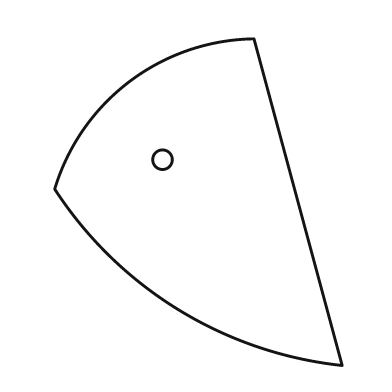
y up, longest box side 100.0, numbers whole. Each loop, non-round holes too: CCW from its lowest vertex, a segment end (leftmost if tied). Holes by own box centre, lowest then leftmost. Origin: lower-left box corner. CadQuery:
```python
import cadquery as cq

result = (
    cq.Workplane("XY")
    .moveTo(88.0, 0.0)
    .lineTo(61.0, 100.0)
    .threePointArc((23.0, 87.0), (0.0, 54.0))
    .threePointArc((38.0, 17.0), (88.0, 0.0))
    .close()
    .moveTo(33.0, 63.0)
    .circle(3.0)
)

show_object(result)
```